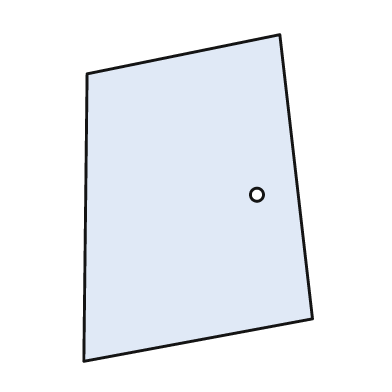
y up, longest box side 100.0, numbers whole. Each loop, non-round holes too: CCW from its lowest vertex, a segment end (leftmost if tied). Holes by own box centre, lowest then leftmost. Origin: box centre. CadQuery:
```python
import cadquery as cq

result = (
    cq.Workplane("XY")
    .moveTo(-35.0, -50.0)
    .lineTo(35.0, -37.0)
    .lineTo(25.0, 50.0)
    .lineTo(-34.0, 38.0)
    .close()
    .moveTo(18.0, 1.0)
    .circle(2.0)
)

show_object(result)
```